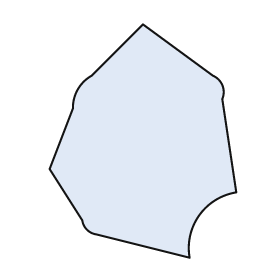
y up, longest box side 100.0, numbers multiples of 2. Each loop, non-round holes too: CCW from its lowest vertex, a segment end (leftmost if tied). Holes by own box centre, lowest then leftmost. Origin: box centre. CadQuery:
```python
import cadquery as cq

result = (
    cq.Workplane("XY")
    .moveTo(20.0, -50.0)
    .threePointArc((24.0, -32.0), (40.0, -22.0))
    .lineTo(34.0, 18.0)
    .threePointArc((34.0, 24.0), (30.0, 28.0))
    .lineTo(0.0, 50.0)
    .lineTo(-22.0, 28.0)
    .threePointArc((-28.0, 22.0), (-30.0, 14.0))
    .lineTo(-40.0, -12.0)
    .lineTo(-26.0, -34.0)
    .threePointArc((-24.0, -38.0), (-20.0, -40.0))
    .close()
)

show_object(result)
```